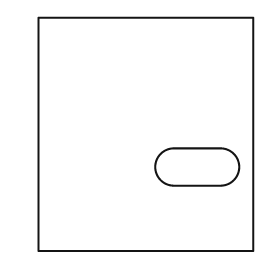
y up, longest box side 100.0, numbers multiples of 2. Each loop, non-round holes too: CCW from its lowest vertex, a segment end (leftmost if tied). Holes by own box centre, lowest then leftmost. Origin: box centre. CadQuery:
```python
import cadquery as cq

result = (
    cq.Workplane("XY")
    .moveTo(-46.0, -50.0)
    .lineTo(46.0, -50.0)
    .lineTo(46.0, 50.0)
    .lineTo(-46.0, 50.0)
    .close()
    .moveTo(12.0, -22.0)
    .lineTo(32.0, -22.0)
    .threePointArc((40.0, -14.0), (32.0, -6.0))
    .lineTo(12.0, -6.0)
    .threePointArc((4.0, -14.0), (12.0, -22.0))
    .close()
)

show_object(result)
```